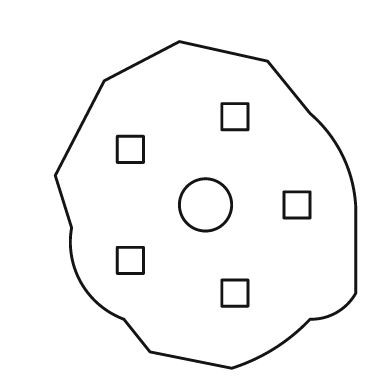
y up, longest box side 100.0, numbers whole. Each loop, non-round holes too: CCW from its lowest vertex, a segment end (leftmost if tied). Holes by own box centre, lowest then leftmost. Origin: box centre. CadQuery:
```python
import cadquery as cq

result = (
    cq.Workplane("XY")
    .moveTo(8.0, -50.0)
    .threePointArc((21.0, -44.0), (32.0, -35.0))
    .threePointArc((40.0, -33.0), (46.0, -27.0))
    .lineTo(46.0, -1.0)
    .threePointArc((42.0, 15.0), (32.0, 28.0))
    .lineTo(19.0, 44.0)
    .lineTo(-8.0, 50.0)
    .lineTo(-31.0, 38.0)
    .lineTo(-46.0, 9.0)
    .lineTo(-41.0, -7.0)
    .threePointArc((-38.0, -24.0), (-25.0, -35.0))
    .lineTo(-17.0, -45.0)
    .close()
    .moveTo(5.0, -31.0)
    .lineTo(13.0, -31.0)
    .lineTo(13.0, -23.0)
    .lineTo(5.0, -23.0)
    .close()
    .moveTo(-27.0, -21.0)
    .lineTo(-19.0, -21.0)
    .lineTo(-19.0, -13.0)
    .lineTo(-27.0, -13.0)
    .close()
    .moveTo(0.0, 0.0)
    .circle(8.0)
    .moveTo(24.0, -4.0)
    .lineTo(32.0, -4.0)
    .lineTo(32.0, 4.0)
    .lineTo(24.0, 4.0)
    .close()
    .moveTo(-27.0, 13.0)
    .lineTo(-19.0, 13.0)
    .lineTo(-19.0, 21.0)
    .lineTo(-27.0, 21.0)
    .close()
    .moveTo(5.0, 23.0)
    .lineTo(13.0, 23.0)
    .lineTo(13.0, 31.0)
    .lineTo(5.0, 31.0)
    .close()
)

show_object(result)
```